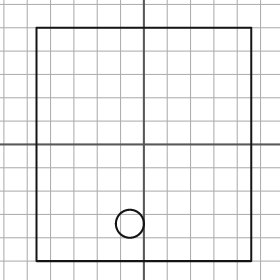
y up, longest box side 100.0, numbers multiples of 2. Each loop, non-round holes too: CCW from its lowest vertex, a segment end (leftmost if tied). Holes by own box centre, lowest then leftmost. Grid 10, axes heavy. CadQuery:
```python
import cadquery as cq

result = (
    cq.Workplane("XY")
    .moveTo(-46.0, -50.0)
    .lineTo(46.0, -50.0)
    .lineTo(46.0, 50.0)
    .lineTo(-46.0, 50.0)
    .close()
    .moveTo(-6.0, -34.0)
    .circle(6.0)
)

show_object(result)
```